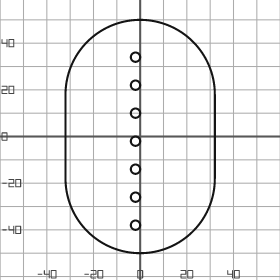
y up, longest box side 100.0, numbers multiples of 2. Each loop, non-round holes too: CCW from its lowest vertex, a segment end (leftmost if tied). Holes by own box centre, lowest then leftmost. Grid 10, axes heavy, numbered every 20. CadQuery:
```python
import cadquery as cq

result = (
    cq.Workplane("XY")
    .moveTo(-32.0, -18.0)
    .threePointArc((0.0, -50.0), (32.0, -18.0))
    .lineTo(32.0, 18.0)
    .threePointArc((0.0, 50.0), (-32.0, 18.0))
    .close()
    .moveTo(-2.0, -38.0)
    .circle(2.0)
    .moveTo(-2.0, -26.0)
    .circle(2.0)
    .moveTo(-2.0, -14.0)
    .circle(2.0)
    .moveTo(-2.0, -2.0)
    .circle(2.0)
    .moveTo(-2.0, 10.0)
    .circle(2.0)
    .moveTo(-2.0, 22.0)
    .circle(2.0)
    .moveTo(-2.0, 34.0)
    .circle(2.0)
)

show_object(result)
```